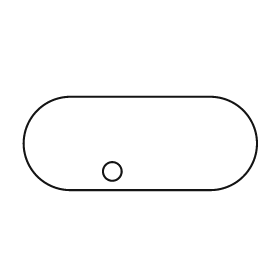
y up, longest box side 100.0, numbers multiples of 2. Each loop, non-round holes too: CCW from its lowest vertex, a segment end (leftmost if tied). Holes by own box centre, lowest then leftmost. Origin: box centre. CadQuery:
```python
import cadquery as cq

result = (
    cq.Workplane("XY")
    .moveTo(-30.0, -20.0)
    .lineTo(30.0, -20.0)
    .threePointArc((50.0, 0.0), (30.0, 20.0))
    .lineTo(-30.0, 20.0)
    .threePointArc((-50.0, 0.0), (-30.0, -20.0))
    .close()
    .moveTo(-12.0, -12.0)
    .circle(4.0)
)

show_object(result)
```